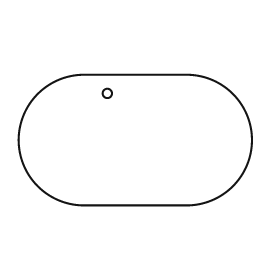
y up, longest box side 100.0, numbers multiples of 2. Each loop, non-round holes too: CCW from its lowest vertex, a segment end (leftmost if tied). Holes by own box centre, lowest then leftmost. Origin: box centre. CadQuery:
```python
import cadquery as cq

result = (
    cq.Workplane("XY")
    .moveTo(-22.0, -28.0)
    .lineTo(22.0, -28.0)
    .threePointArc((50.0, 0.0), (22.0, 28.0))
    .lineTo(-22.0, 28.0)
    .threePointArc((-50.0, 0.0), (-22.0, -28.0))
    .close()
    .moveTo(-12.0, 20.0)
    .circle(2.0)
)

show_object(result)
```